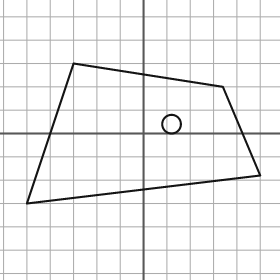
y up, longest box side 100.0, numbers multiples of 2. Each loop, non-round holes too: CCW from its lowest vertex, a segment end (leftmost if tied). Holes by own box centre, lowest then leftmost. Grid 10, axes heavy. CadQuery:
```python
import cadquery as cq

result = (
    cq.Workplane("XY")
    .moveTo(-50.0, -30.0)
    .lineTo(50.0, -18.0)
    .lineTo(34.0, 20.0)
    .lineTo(-30.0, 30.0)
    .close()
    .moveTo(12.0, 4.0)
    .circle(4.0)
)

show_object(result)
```